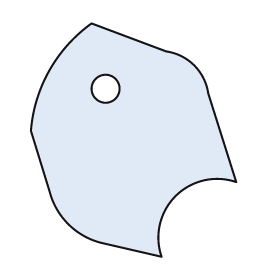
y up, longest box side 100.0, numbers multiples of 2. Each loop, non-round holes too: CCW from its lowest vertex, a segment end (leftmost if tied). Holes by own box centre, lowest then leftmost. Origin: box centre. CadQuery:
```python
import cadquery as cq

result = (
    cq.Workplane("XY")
    .moveTo(12.0, -50.0)
    .threePointArc((18.0, -24.0), (44.0, -18.0))
    .lineTo(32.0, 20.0)
    .threePointArc((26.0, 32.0), (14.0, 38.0))
    .lineTo(-18.0, 50.0)
    .threePointArc((-36.0, 30.0), (-44.0, 4.0))
    .lineTo(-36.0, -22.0)
    .threePointArc((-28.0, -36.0), (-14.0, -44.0))
    .close()
    .moveTo(-12.0, 22.0)
    .circle(6.0)
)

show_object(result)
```